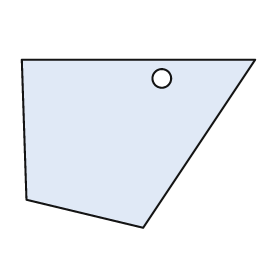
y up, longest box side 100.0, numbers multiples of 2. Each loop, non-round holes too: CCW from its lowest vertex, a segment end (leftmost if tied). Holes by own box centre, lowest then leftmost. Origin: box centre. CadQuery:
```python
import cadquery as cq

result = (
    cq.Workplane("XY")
    .moveTo(2.0, -36.0)
    .lineTo(50.0, 36.0)
    .lineTo(-50.0, 36.0)
    .lineTo(-48.0, -24.0)
    .close()
    .moveTo(10.0, 28.0)
    .circle(4.0)
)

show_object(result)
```